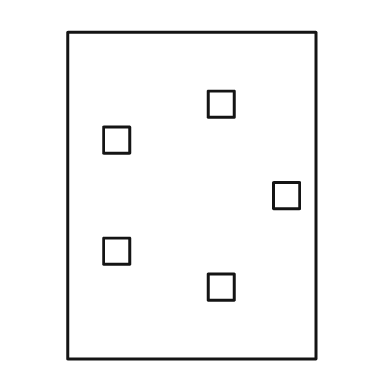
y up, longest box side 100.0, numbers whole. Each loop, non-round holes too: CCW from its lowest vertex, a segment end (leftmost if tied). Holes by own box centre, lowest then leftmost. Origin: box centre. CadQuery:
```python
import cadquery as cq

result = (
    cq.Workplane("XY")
    .moveTo(-38.0, -50.0)
    .lineTo(38.0, -50.0)
    .lineTo(38.0, 50.0)
    .lineTo(-38.0, 50.0)
    .close()
    .moveTo(5.0, -32.0)
    .lineTo(13.0, -32.0)
    .lineTo(13.0, -24.0)
    .lineTo(5.0, -24.0)
    .close()
    .moveTo(-27.0, -21.0)
    .lineTo(-19.0, -21.0)
    .lineTo(-19.0, -13.0)
    .lineTo(-27.0, -13.0)
    .close()
    .moveTo(25.0, -4.0)
    .lineTo(33.0, -4.0)
    .lineTo(33.0, 4.0)
    .lineTo(25.0, 4.0)
    .close()
    .moveTo(-27.0, 13.0)
    .lineTo(-19.0, 13.0)
    .lineTo(-19.0, 21.0)
    .lineTo(-27.0, 21.0)
    .close()
    .moveTo(5.0, 24.0)
    .lineTo(13.0, 24.0)
    .lineTo(13.0, 32.0)
    .lineTo(5.0, 32.0)
    .close()
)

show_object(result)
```